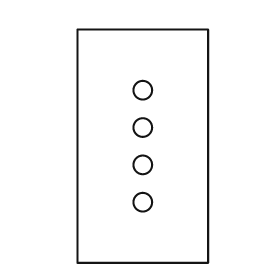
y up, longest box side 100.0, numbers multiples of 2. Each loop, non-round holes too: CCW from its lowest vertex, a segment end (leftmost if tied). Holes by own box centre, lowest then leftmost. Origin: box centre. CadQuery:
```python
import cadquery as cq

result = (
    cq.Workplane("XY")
    .moveTo(-28.0, -50.0)
    .lineTo(28.0, -50.0)
    .lineTo(28.0, 50.0)
    .lineTo(-28.0, 50.0)
    .close()
    .moveTo(0.0, -24.0)
    .circle(4.0)
    .moveTo(0.0, -8.0)
    .circle(4.0)
    .moveTo(0.0, 8.0)
    .circle(4.0)
    .moveTo(0.0, 24.0)
    .circle(4.0)
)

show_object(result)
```